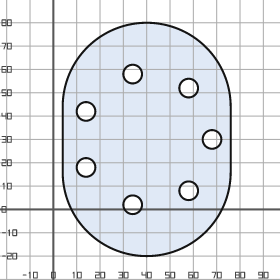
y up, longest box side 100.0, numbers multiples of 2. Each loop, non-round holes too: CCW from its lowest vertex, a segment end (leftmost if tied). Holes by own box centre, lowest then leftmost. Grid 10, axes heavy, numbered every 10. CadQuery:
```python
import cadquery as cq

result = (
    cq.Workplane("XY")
    .moveTo(4.0, 16.0)
    .threePointArc((40.0, -20.0), (76.0, 16.0))
    .lineTo(76.0, 44.0)
    .threePointArc((40.0, 80.0), (4.0, 44.0))
    .close()
    .moveTo(34.0, 2.0)
    .circle(4.0)
    .moveTo(58.0, 8.0)
    .circle(4.0)
    .moveTo(14.0, 18.0)
    .circle(4.0)
    .moveTo(68.0, 30.0)
    .circle(4.0)
    .moveTo(14.0, 42.0)
    .circle(4.0)
    .moveTo(58.0, 52.0)
    .circle(4.0)
    .moveTo(34.0, 58.0)
    .circle(4.0)
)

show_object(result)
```